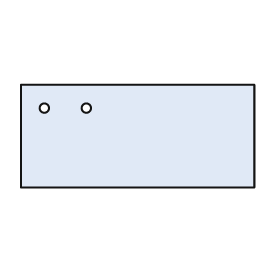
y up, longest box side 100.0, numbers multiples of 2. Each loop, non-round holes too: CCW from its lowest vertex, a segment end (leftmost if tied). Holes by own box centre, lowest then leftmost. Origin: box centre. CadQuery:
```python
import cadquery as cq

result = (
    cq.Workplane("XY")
    .moveTo(-50.0, -22.0)
    .lineTo(50.0, -22.0)
    .lineTo(50.0, 22.0)
    .lineTo(-50.0, 22.0)
    .close()
    .moveTo(-40.0, 12.0)
    .circle(2.0)
    .moveTo(-22.0, 12.0)
    .circle(2.0)
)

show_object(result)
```